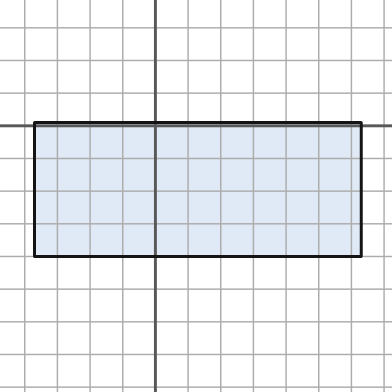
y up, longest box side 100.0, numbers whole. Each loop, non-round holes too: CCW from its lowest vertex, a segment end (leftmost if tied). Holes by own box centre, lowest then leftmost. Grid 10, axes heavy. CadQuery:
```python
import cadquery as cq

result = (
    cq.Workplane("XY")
    .moveTo(-37.0, -40.0)
    .lineTo(63.0, -40.0)
    .lineTo(63.0, 1.0)
    .lineTo(-37.0, 1.0)
    .close()
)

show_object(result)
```